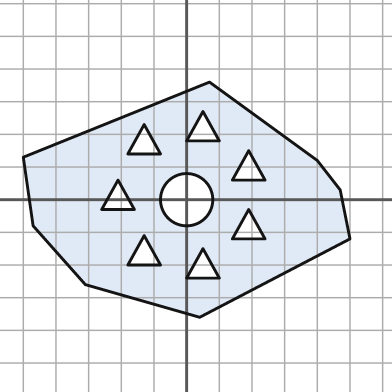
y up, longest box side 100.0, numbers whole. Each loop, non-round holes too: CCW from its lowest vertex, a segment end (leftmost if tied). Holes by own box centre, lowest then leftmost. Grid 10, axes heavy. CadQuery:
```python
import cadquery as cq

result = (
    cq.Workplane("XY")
    .moveTo(4.0, -36.0)
    .lineTo(50.0, -12.0)
    .lineTo(47.0, 3.0)
    .lineTo(40.0, 12.0)
    .lineTo(7.0, 36.0)
    .lineTo(-50.0, 13.0)
    .lineTo(-47.0, -8.0)
    .lineTo(-31.0, -26.0)
    .close()
    .moveTo(0.0, -24.0)
    .lineTo(10.0, -24.0)
    .lineTo(5.0, -15.0)
    .close()
    .moveTo(-18.0, -20.0)
    .lineTo(-8.0, -20.0)
    .lineTo(-13.0, -11.0)
    .close()
    .moveTo(14.0, -12.0)
    .lineTo(24.0, -12.0)
    .lineTo(19.0, -3.0)
    .close()
    .moveTo(0.0, 0.0)
    .circle(8.0)
    .moveTo(-26.0, -3.0)
    .lineTo(-16.0, -3.0)
    .lineTo(-21.0, 6.0)
    .close()
    .moveTo(14.0, 6.0)
    .lineTo(24.0, 6.0)
    .lineTo(19.0, 15.0)
    .close()
    .moveTo(-18.0, 14.0)
    .lineTo(-8.0, 14.0)
    .lineTo(-13.0, 23.0)
    .close()
    .moveTo(0.0, 18.0)
    .lineTo(10.0, 18.0)
    .lineTo(5.0, 27.0)
    .close()
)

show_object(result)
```